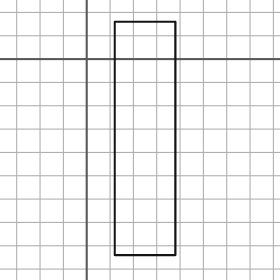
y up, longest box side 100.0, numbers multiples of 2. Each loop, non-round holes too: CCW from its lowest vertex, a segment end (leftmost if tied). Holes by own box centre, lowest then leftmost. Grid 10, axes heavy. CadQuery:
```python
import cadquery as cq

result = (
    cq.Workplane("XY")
    .moveTo(12.0, -84.0)
    .lineTo(38.0, -84.0)
    .lineTo(38.0, 16.0)
    .lineTo(12.0, 16.0)
    .close()
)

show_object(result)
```